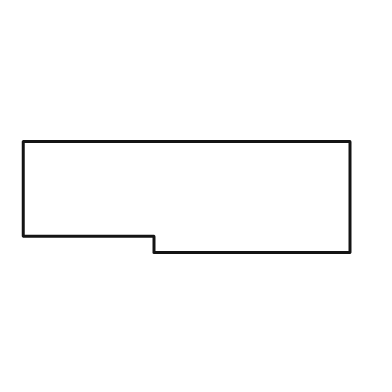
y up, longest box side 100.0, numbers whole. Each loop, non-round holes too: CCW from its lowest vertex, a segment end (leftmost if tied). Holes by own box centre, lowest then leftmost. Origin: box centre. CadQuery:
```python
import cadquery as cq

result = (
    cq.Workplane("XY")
    .moveTo(-10.0, -17.0)
    .lineTo(50.0, -17.0)
    .lineTo(50.0, 17.0)
    .lineTo(-50.0, 17.0)
    .lineTo(-50.0, -12.0)
    .lineTo(-10.0, -12.0)
    .close()
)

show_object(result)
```